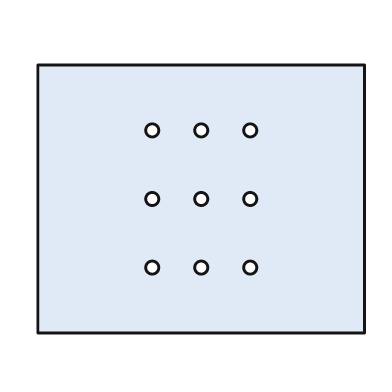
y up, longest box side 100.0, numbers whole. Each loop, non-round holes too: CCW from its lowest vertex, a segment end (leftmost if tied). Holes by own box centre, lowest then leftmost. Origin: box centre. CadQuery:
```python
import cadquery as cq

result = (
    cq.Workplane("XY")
    .moveTo(-50.0, -41.0)
    .lineTo(50.0, -41.0)
    .lineTo(50.0, 41.0)
    .lineTo(-50.0, 41.0)
    .close()
    .moveTo(-15.0, -21.0)
    .circle(2.0)
    .moveTo(0.0, -21.0)
    .circle(2.0)
    .moveTo(15.0, -21.0)
    .circle(2.0)
    .moveTo(-15.0, 0.0)
    .circle(2.0)
    .moveTo(0.0, 0.0)
    .circle(2.0)
    .moveTo(15.0, 0.0)
    .circle(2.0)
    .moveTo(-15.0, 21.0)
    .circle(2.0)
    .moveTo(0.0, 21.0)
    .circle(2.0)
    .moveTo(15.0, 21.0)
    .circle(2.0)
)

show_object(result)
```